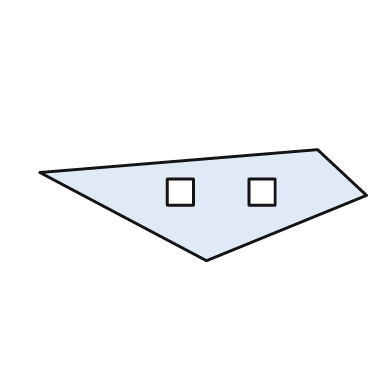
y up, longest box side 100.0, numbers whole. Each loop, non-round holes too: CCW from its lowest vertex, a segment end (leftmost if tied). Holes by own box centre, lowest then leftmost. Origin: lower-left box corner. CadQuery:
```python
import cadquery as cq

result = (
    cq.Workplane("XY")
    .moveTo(51.0, 0.0)
    .lineTo(100.0, 20.0)
    .lineTo(85.0, 34.0)
    .lineTo(0.0, 27.0)
    .close()
    .moveTo(39.0, 17.0)
    .lineTo(47.0, 17.0)
    .lineTo(47.0, 25.0)
    .lineTo(39.0, 25.0)
    .close()
    .moveTo(64.0, 17.0)
    .lineTo(72.0, 17.0)
    .lineTo(72.0, 25.0)
    .lineTo(64.0, 25.0)
    .close()
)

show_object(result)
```